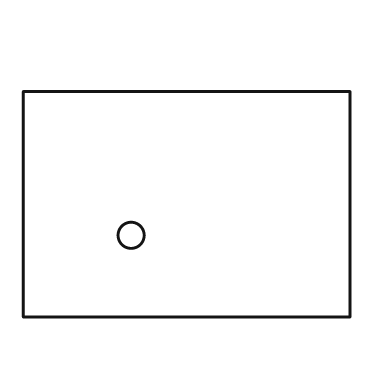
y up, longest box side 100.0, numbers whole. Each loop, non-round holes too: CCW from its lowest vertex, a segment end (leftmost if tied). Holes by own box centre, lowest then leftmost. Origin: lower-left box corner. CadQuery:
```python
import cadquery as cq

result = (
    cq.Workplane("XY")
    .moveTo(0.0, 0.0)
    .lineTo(100.0, 0.0)
    .lineTo(100.0, 69.0)
    .lineTo(0.0, 69.0)
    .close()
    .moveTo(33.0, 25.0)
    .circle(4.0)
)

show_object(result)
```